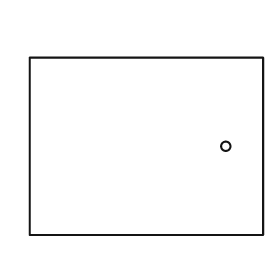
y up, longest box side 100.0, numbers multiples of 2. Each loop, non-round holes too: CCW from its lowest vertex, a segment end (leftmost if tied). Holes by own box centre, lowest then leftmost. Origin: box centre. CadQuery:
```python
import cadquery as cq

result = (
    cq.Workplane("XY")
    .moveTo(-50.0, -38.0)
    .lineTo(50.0, -38.0)
    .lineTo(50.0, 38.0)
    .lineTo(-50.0, 38.0)
    .close()
    .moveTo(34.0, 0.0)
    .circle(2.0)
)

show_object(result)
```